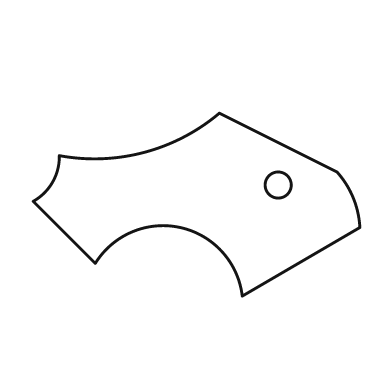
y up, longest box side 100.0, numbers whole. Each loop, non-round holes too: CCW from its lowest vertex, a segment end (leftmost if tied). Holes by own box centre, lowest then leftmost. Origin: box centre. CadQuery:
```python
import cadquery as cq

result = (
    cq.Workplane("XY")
    .moveTo(14.0, -28.0)
    .lineTo(50.0, -7.0)
    .threePointArc((48.0, 2.0), (43.0, 10.0))
    .lineTo(7.0, 28.0)
    .threePointArc((-16.0, 16.0), (-42.0, 15.0))
    .threePointArc((-44.0, 7.0), (-50.0, 1.0))
    .lineTo(-31.0, -18.0)
    .threePointArc((-5.0, -7.0), (14.0, -28.0))
    .close()
    .moveTo(25.0, 6.0)
    .circle(4.0)
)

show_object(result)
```